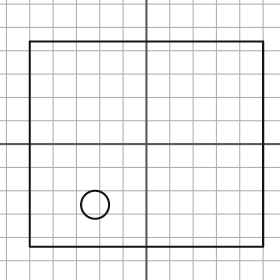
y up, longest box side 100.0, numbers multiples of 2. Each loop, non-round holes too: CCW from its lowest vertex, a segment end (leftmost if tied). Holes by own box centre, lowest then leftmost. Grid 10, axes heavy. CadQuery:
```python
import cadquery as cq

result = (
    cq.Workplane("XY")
    .moveTo(-50.0, -44.0)
    .lineTo(50.0, -44.0)
    .lineTo(50.0, 44.0)
    .lineTo(-50.0, 44.0)
    .close()
    .moveTo(-22.0, -26.0)
    .circle(6.0)
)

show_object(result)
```